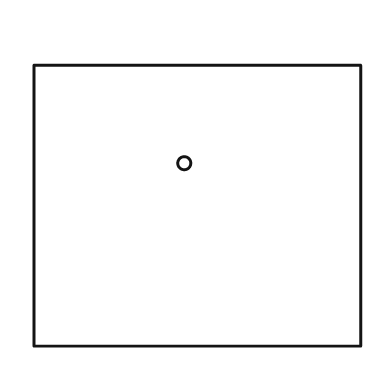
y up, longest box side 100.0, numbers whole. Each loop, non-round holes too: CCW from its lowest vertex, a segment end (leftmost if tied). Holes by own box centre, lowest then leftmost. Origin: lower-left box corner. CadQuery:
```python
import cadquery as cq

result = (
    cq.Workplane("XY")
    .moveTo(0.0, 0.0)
    .lineTo(100.0, 0.0)
    .lineTo(100.0, 86.0)
    .lineTo(0.0, 86.0)
    .close()
    .moveTo(46.0, 56.0)
    .circle(2.0)
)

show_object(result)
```